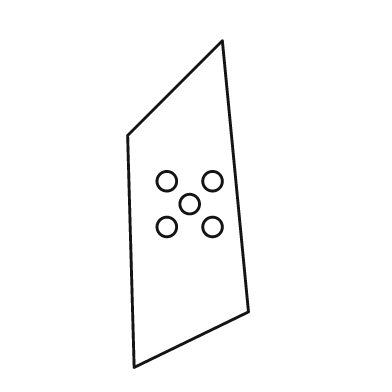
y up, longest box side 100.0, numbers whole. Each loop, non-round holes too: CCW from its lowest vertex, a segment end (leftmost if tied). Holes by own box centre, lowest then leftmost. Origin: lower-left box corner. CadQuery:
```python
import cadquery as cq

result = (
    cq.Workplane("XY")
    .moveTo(2.0, 0.0)
    .lineTo(37.0, 17.0)
    .lineTo(29.0, 100.0)
    .lineTo(0.0, 71.0)
    .close()
    .moveTo(12.0, 43.0)
    .circle(3.0)
    .moveTo(26.0, 43.0)
    .circle(3.0)
    .moveTo(19.0, 50.0)
    .circle(3.0)
    .moveTo(12.0, 57.0)
    .circle(3.0)
    .moveTo(26.0, 57.0)
    .circle(3.0)
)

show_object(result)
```